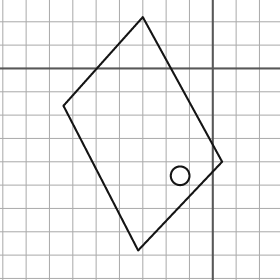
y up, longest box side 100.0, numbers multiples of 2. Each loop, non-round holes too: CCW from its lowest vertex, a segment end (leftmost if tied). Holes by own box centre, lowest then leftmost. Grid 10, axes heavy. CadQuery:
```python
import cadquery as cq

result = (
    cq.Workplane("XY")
    .moveTo(-32.0, -78.0)
    .lineTo(4.0, -40.0)
    .lineTo(-30.0, 22.0)
    .lineTo(-64.0, -16.0)
    .close()
    .moveTo(-14.0, -46.0)
    .circle(4.0)
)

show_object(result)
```